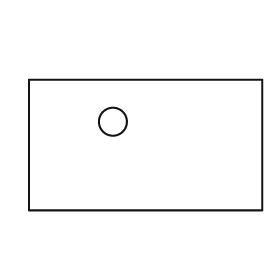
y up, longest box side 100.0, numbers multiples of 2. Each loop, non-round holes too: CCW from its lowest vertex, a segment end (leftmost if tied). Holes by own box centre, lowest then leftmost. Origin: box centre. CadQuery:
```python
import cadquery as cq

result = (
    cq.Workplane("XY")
    .moveTo(-50.0, -28.0)
    .lineTo(50.0, -28.0)
    .lineTo(50.0, 28.0)
    .lineTo(-50.0, 28.0)
    .close()
    .moveTo(-14.0, 10.0)
    .circle(6.0)
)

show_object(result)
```